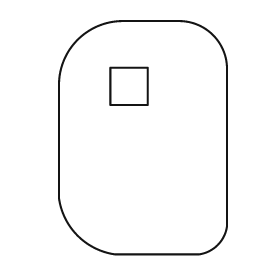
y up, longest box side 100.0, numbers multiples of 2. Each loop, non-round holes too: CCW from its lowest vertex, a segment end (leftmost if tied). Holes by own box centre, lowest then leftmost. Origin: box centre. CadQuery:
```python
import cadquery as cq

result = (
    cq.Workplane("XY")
    .moveTo(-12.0, -50.0)
    .lineTo(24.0, -50.0)
    .threePointArc((32.0, -46.0), (36.0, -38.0))
    .lineTo(36.0, 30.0)
    .threePointArc((30.0, 44.0), (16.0, 50.0))
    .lineTo(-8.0, 50.0)
    .threePointArc((-28.0, 42.0), (-36.0, 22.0))
    .lineTo(-36.0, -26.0)
    .threePointArc((-28.0, -42.0), (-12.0, -50.0))
    .close()
    .moveTo(-14.0, 14.0)
    .lineTo(2.0, 14.0)
    .lineTo(2.0, 30.0)
    .lineTo(-14.0, 30.0)
    .close()
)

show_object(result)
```